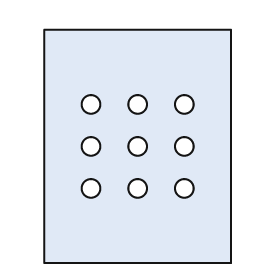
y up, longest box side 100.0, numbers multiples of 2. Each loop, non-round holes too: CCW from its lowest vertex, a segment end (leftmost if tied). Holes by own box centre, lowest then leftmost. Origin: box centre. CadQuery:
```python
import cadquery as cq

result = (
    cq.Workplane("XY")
    .moveTo(-40.0, -50.0)
    .lineTo(40.0, -50.0)
    .lineTo(40.0, 50.0)
    .lineTo(-40.0, 50.0)
    .close()
    .moveTo(-20.0, -18.0)
    .circle(4.0)
    .moveTo(0.0, -18.0)
    .circle(4.0)
    .moveTo(20.0, -18.0)
    .circle(4.0)
    .moveTo(-20.0, 0.0)
    .circle(4.0)
    .moveTo(0.0, 0.0)
    .circle(4.0)
    .moveTo(20.0, 0.0)
    .circle(4.0)
    .moveTo(-20.0, 18.0)
    .circle(4.0)
    .moveTo(0.0, 18.0)
    .circle(4.0)
    .moveTo(20.0, 18.0)
    .circle(4.0)
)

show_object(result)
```